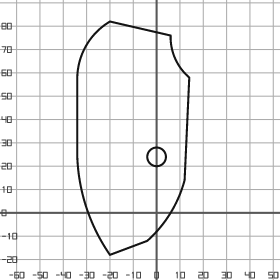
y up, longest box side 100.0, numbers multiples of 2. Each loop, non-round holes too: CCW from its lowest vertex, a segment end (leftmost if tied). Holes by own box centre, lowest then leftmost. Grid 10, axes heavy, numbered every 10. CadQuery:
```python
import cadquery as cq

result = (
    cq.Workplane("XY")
    .moveTo(-20.0, -18.0)
    .lineTo(-4.0, -12.0)
    .threePointArc((6.0, 0.0), (12.0, 14.0))
    .lineTo(14.0, 58.0)
    .threePointArc((8.0, 66.0), (6.0, 76.0))
    .lineTo(-20.0, 82.0)
    .threePointArc((-30.0, 72.0), (-34.0, 58.0))
    .lineTo(-34.0, 24.0)
    .threePointArc((-30.0, 2.0), (-20.0, -18.0))
    .close()
    .moveTo(0.0, 24.0)
    .circle(4.0)
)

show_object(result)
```